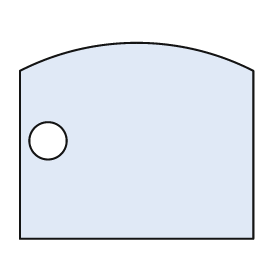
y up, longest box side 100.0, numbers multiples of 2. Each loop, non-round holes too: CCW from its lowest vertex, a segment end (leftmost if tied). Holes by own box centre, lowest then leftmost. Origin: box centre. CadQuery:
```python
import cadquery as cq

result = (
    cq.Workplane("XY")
    .moveTo(-50.0, -42.0)
    .lineTo(50.0, -42.0)
    .lineTo(50.0, 30.0)
    .threePointArc((0.0, 42.0), (-50.0, 30.0))
    .close()
    .moveTo(-38.0, 0.0)
    .circle(8.0)
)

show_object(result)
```